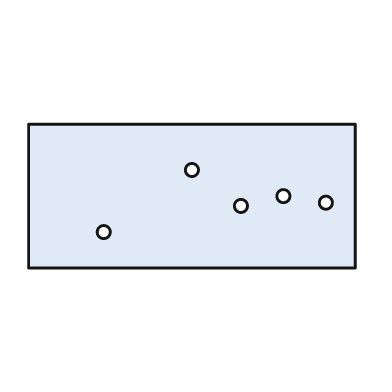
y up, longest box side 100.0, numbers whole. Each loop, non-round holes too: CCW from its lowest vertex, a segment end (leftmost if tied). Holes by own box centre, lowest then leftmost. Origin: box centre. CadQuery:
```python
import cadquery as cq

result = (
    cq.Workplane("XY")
    .moveTo(-50.0, -22.0)
    .lineTo(50.0, -22.0)
    .lineTo(50.0, 22.0)
    .lineTo(-50.0, 22.0)
    .close()
    .moveTo(-27.0, -11.0)
    .circle(2.0)
    .moveTo(15.0, -3.0)
    .circle(2.0)
    .moveTo(41.0, -2.0)
    .circle(2.0)
    .moveTo(28.0, 0.0)
    .circle(2.0)
    .moveTo(0.0, 8.0)
    .circle(2.0)
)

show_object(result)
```